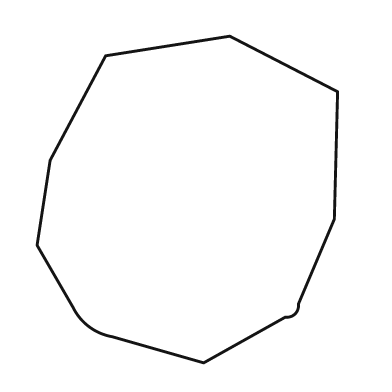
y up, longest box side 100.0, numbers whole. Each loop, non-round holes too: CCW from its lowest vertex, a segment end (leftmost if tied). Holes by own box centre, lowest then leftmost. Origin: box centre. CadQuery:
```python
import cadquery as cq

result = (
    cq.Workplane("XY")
    .moveTo(5.0, -50.0)
    .lineTo(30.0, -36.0)
    .threePointArc((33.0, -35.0), (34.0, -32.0))
    .lineTo(45.0, -6.0)
    .lineTo(46.0, 33.0)
    .lineTo(13.0, 50.0)
    .lineTo(-25.0, 44.0)
    .lineTo(-42.0, 12.0)
    .lineTo(-46.0, -14.0)
    .lineTo(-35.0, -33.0)
    .threePointArc((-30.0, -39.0), (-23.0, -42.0))
    .close()
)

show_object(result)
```